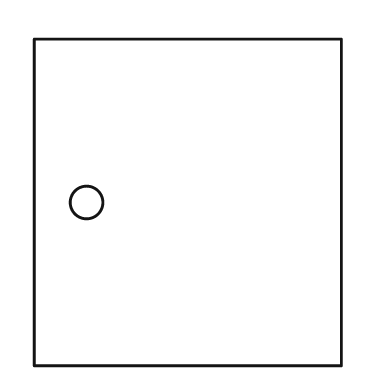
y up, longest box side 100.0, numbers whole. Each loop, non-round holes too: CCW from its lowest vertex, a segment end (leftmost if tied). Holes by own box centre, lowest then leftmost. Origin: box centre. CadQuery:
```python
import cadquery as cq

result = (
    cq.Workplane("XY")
    .moveTo(-47.0, -50.0)
    .lineTo(47.0, -50.0)
    .lineTo(47.0, 50.0)
    .lineTo(-47.0, 50.0)
    .close()
    .moveTo(-31.0, 0.0)
    .circle(5.0)
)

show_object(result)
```